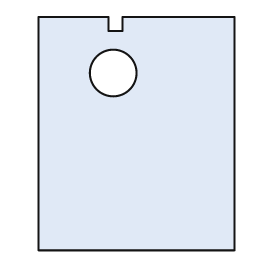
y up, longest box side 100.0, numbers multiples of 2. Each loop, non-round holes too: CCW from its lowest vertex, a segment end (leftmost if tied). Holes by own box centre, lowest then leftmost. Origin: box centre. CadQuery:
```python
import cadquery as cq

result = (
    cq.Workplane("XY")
    .moveTo(-42.0, -50.0)
    .lineTo(42.0, -50.0)
    .lineTo(42.0, 50.0)
    .lineTo(-6.0, 50.0)
    .lineTo(-6.0, 44.0)
    .lineTo(-12.0, 44.0)
    .lineTo(-12.0, 50.0)
    .lineTo(-42.0, 50.0)
    .close()
    .moveTo(-10.0, 26.0)
    .circle(10.0)
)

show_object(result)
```